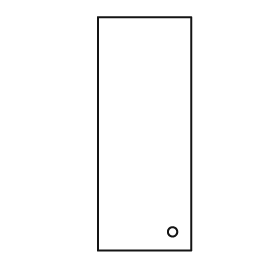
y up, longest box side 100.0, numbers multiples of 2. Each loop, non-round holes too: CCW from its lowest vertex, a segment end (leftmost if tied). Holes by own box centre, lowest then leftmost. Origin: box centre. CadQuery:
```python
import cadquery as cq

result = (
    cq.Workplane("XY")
    .moveTo(-20.0, -50.0)
    .lineTo(20.0, -50.0)
    .lineTo(20.0, 50.0)
    .lineTo(-20.0, 50.0)
    .close()
    .moveTo(12.0, -42.0)
    .circle(2.0)
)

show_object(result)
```